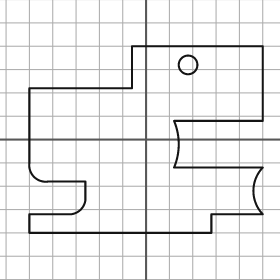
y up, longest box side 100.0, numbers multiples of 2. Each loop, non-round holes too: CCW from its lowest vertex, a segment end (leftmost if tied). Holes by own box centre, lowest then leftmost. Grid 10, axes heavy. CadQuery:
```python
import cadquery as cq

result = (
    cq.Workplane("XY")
    .moveTo(-50.0, -40.0)
    .lineTo(28.0, -40.0)
    .lineTo(28.0, -32.0)
    .lineTo(50.0, -32.0)
    .threePointArc((46.0, -22.0), (50.0, -12.0))
    .lineTo(12.0, -12.0)
    .threePointArc((14.0, -2.0), (12.0, 8.0))
    .lineTo(50.0, 8.0)
    .lineTo(50.0, 40.0)
    .lineTo(-6.0, 40.0)
    .lineTo(-6.0, 22.0)
    .lineTo(-50.0, 22.0)
    .lineTo(-50.0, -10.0)
    .threePointArc((-48.0, -16.0), (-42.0, -18.0))
    .lineTo(-26.0, -18.0)
    .lineTo(-26.0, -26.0)
    .threePointArc((-28.0, -30.0), (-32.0, -32.0))
    .lineTo(-50.0, -32.0)
    .close()
    .moveTo(18.0, 32.0)
    .circle(4.0)
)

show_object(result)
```